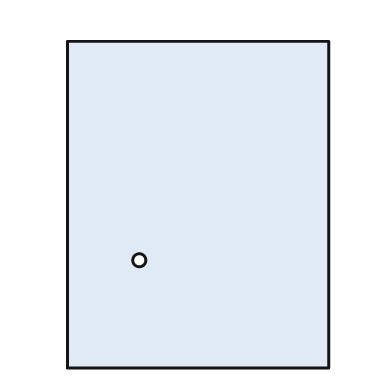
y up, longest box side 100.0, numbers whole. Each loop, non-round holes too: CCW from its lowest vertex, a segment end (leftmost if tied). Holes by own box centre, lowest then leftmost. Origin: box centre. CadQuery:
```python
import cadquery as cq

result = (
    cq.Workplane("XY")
    .moveTo(-40.0, -50.0)
    .lineTo(40.0, -50.0)
    .lineTo(40.0, 50.0)
    .lineTo(-40.0, 50.0)
    .close()
    .moveTo(-18.0, -17.0)
    .circle(2.0)
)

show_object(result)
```